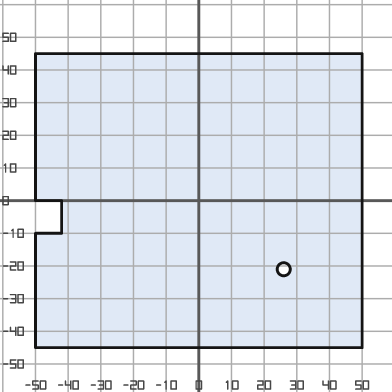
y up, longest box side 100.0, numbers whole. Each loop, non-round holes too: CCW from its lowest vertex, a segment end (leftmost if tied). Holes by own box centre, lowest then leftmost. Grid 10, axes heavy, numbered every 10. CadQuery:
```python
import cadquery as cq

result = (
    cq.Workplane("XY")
    .moveTo(-50.0, -45.0)
    .lineTo(50.0, -45.0)
    .lineTo(50.0, 45.0)
    .lineTo(-50.0, 45.0)
    .lineTo(-50.0, 0.0)
    .lineTo(-42.0, 0.0)
    .lineTo(-42.0, -10.0)
    .lineTo(-50.0, -10.0)
    .close()
    .moveTo(26.0, -21.0)
    .circle(2.0)
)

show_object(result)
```